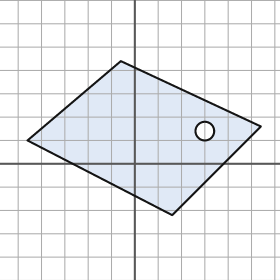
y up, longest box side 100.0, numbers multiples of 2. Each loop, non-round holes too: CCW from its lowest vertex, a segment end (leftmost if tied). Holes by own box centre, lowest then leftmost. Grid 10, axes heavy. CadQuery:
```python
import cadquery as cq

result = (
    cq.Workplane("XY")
    .moveTo(16.0, -22.0)
    .lineTo(54.0, 16.0)
    .lineTo(-6.0, 44.0)
    .lineTo(-46.0, 10.0)
    .close()
    .moveTo(30.0, 14.0)
    .circle(4.0)
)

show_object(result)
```